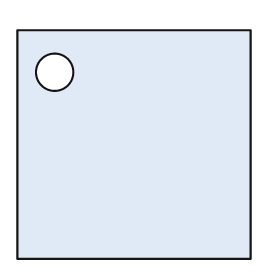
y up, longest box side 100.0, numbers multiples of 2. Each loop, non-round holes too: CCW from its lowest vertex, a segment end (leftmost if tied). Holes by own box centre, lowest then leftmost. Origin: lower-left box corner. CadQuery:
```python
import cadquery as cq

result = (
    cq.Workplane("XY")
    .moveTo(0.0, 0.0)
    .lineTo(100.0, 0.0)
    .lineTo(100.0, 98.0)
    .lineTo(0.0, 98.0)
    .close()
    .moveTo(16.0, 80.0)
    .circle(8.0)
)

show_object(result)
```